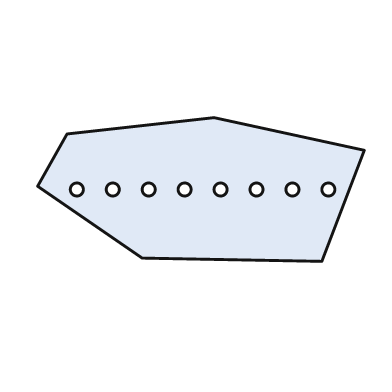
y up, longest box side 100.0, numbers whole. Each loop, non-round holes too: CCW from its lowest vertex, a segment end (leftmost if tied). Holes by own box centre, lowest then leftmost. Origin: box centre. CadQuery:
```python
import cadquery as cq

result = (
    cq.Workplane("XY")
    .moveTo(37.0, -22.0)
    .lineTo(50.0, 12.0)
    .lineTo(4.0, 22.0)
    .lineTo(-41.0, 17.0)
    .lineTo(-50.0, 1.0)
    .lineTo(-18.0, -21.0)
    .close()
    .moveTo(-38.0, 0.0)
    .circle(2.0)
    .moveTo(-27.0, 0.0)
    .circle(2.0)
    .moveTo(-16.0, 0.0)
    .circle(2.0)
    .moveTo(-5.0, 0.0)
    .circle(2.0)
    .moveTo(6.0, 0.0)
    .circle(2.0)
    .moveTo(17.0, 0.0)
    .circle(2.0)
    .moveTo(28.0, 0.0)
    .circle(2.0)
    .moveTo(39.0, 0.0)
    .circle(2.0)
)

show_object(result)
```